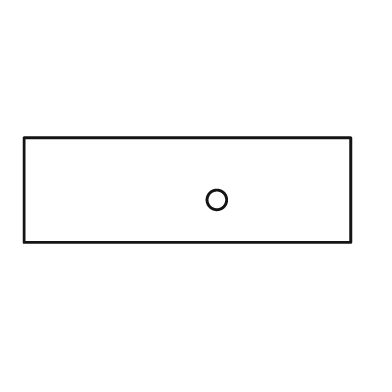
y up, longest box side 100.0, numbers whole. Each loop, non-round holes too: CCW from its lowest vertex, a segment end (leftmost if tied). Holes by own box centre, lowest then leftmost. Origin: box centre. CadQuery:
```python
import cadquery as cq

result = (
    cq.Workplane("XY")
    .moveTo(-50.0, -16.0)
    .lineTo(50.0, -16.0)
    .lineTo(50.0, 16.0)
    .lineTo(-50.0, 16.0)
    .close()
    .moveTo(9.0, -3.0)
    .circle(3.0)
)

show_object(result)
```